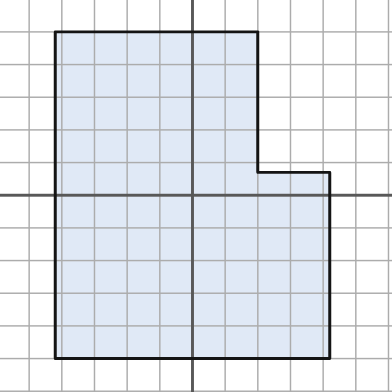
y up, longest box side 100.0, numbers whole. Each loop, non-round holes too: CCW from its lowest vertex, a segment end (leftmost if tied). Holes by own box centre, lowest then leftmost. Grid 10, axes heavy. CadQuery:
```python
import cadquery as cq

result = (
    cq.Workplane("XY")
    .moveTo(-42.0, -50.0)
    .lineTo(42.0, -50.0)
    .lineTo(42.0, 7.0)
    .lineTo(20.0, 7.0)
    .lineTo(20.0, 50.0)
    .lineTo(-42.0, 50.0)
    .close()
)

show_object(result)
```